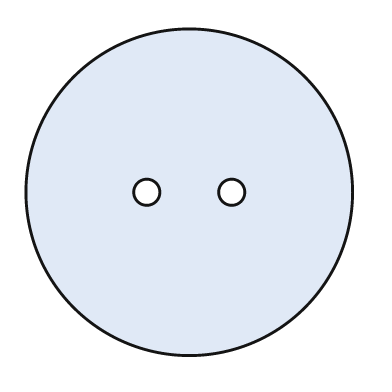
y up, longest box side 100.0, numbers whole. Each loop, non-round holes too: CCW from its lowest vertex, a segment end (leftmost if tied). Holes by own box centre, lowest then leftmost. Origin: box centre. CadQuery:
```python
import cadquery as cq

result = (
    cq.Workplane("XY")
    .moveTo(0.0, 0.0)
    .circle(50.0)
    .moveTo(-13.0, 0.0)
    .circle(4.0)
    .moveTo(13.0, 0.0)
    .circle(4.0)
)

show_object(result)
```